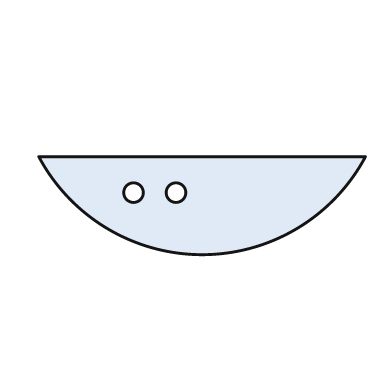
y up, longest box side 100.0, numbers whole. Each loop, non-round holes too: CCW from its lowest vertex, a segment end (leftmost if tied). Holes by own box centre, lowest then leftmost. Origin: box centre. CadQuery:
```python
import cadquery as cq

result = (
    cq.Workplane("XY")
    .moveTo(-50.0, 15.0)
    .threePointArc((0.0, -15.0), (50.0, 15.0))
    .close()
    .moveTo(-21.0, 4.0)
    .circle(3.0)
    .moveTo(-8.0, 4.0)
    .circle(3.0)
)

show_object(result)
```